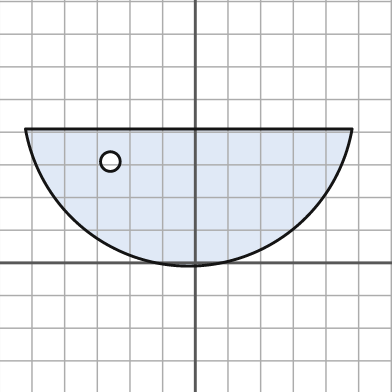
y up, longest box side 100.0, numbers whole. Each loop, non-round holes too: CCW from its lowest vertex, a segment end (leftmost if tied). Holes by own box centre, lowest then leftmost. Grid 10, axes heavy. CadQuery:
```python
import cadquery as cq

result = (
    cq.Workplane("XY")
    .moveTo(-52.0, 41.0)
    .threePointArc((-2.0, -1.0), (48.0, 41.0))
    .close()
    .moveTo(-26.0, 31.0)
    .circle(3.0)
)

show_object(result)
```